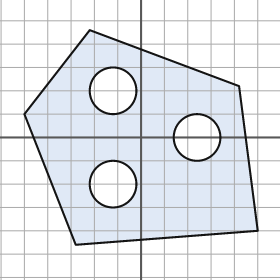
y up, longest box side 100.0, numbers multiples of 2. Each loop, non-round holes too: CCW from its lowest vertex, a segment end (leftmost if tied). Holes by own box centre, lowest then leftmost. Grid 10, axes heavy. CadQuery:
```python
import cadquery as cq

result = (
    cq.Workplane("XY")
    .moveTo(-28.0, -46.0)
    .lineTo(50.0, -40.0)
    .lineTo(42.0, 22.0)
    .lineTo(-22.0, 46.0)
    .lineTo(-50.0, 10.0)
    .close()
    .moveTo(-12.0, -20.0)
    .circle(10.0)
    .moveTo(24.0, 0.0)
    .circle(10.0)
    .moveTo(-12.0, 20.0)
    .circle(10.0)
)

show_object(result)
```